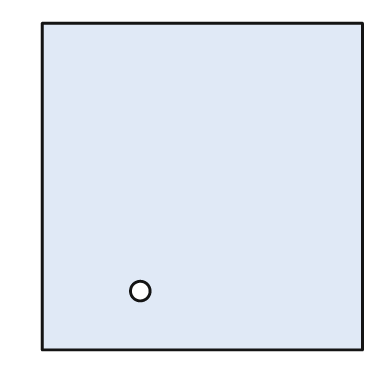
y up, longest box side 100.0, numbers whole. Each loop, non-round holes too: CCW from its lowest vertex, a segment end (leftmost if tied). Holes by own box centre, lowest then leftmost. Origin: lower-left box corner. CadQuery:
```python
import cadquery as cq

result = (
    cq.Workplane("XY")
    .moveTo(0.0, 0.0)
    .lineTo(98.0, 0.0)
    .lineTo(98.0, 100.0)
    .lineTo(0.0, 100.0)
    .close()
    .moveTo(30.0, 18.0)
    .circle(3.0)
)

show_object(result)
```